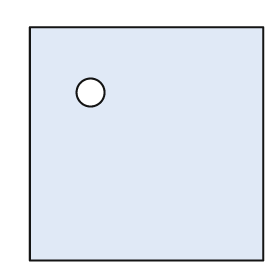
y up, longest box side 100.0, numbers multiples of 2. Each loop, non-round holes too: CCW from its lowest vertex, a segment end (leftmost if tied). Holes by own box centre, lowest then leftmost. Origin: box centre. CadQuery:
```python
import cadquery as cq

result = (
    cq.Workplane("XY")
    .moveTo(-50.0, -50.0)
    .lineTo(50.0, -50.0)
    .lineTo(50.0, 50.0)
    .lineTo(-50.0, 50.0)
    .close()
    .moveTo(-24.0, 22.0)
    .circle(6.0)
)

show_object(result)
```